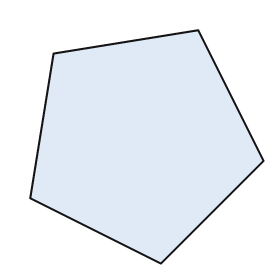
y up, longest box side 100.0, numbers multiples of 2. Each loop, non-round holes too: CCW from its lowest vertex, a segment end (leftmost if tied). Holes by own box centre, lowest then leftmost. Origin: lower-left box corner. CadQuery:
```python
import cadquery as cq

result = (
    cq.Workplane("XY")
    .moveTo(56.0, 0.0)
    .lineTo(100.0, 44.0)
    .lineTo(72.0, 100.0)
    .lineTo(10.0, 90.0)
    .lineTo(0.0, 28.0)
    .close()
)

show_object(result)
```